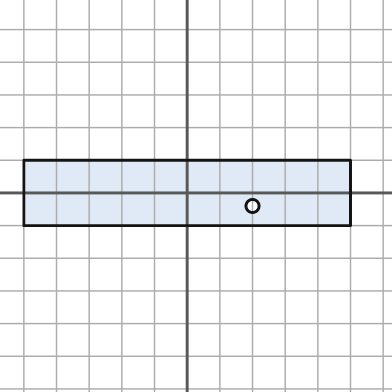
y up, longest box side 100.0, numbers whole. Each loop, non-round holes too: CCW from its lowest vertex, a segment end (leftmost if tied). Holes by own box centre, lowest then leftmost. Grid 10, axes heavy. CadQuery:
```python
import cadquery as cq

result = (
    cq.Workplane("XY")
    .moveTo(-50.0, -10.0)
    .lineTo(50.0, -10.0)
    .lineTo(50.0, 10.0)
    .lineTo(-50.0, 10.0)
    .close()
    .moveTo(20.0, -4.0)
    .circle(2.0)
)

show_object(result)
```